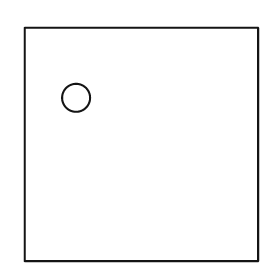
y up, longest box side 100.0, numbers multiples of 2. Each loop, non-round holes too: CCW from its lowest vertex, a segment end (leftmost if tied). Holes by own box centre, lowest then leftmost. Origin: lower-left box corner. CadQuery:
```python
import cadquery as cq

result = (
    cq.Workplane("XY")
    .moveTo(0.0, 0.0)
    .lineTo(100.0, 0.0)
    .lineTo(100.0, 100.0)
    .lineTo(0.0, 100.0)
    .close()
    .moveTo(22.0, 70.0)
    .circle(6.0)
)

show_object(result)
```